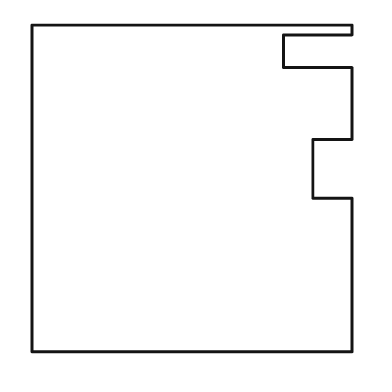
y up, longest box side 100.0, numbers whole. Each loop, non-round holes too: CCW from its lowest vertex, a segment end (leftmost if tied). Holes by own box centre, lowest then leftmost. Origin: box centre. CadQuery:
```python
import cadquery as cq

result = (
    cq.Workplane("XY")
    .moveTo(-49.0, -50.0)
    .lineTo(49.0, -50.0)
    .lineTo(49.0, -3.0)
    .lineTo(37.0, -3.0)
    .lineTo(37.0, 15.0)
    .lineTo(49.0, 15.0)
    .lineTo(49.0, 37.0)
    .lineTo(28.0, 37.0)
    .lineTo(28.0, 47.0)
    .lineTo(49.0, 47.0)
    .lineTo(49.0, 50.0)
    .lineTo(-49.0, 50.0)
    .close()
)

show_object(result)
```